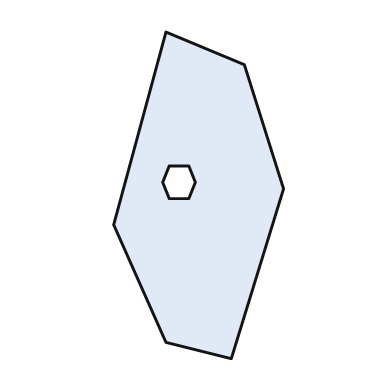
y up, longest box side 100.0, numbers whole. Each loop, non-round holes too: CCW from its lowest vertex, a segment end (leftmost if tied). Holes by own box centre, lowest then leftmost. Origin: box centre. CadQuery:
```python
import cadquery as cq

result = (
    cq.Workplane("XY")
    .moveTo(10.0, -50.0)
    .lineTo(26.0, 2.0)
    .lineTo(14.0, 40.0)
    .lineTo(-10.0, 50.0)
    .lineTo(-26.0, -9.0)
    .lineTo(-10.0, -45.0)
    .close()
    .moveTo(-9.0, -1.0)
    .lineTo(-3.0, -1.0)
    .lineTo(-1.0, 4.0)
    .lineTo(-3.0, 9.0)
    .lineTo(-9.0, 9.0)
    .lineTo(-11.0, 4.0)
    .close()
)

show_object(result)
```